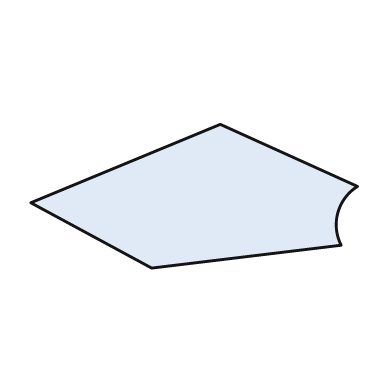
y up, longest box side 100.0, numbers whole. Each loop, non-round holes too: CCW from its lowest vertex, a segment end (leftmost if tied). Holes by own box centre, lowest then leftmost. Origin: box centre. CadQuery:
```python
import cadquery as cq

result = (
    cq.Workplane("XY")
    .moveTo(-13.0, -22.0)
    .lineTo(45.0, -15.0)
    .threePointArc((44.0, -5.0), (50.0, 3.0))
    .lineTo(8.0, 22.0)
    .lineTo(-50.0, -2.0)
    .close()
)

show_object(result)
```